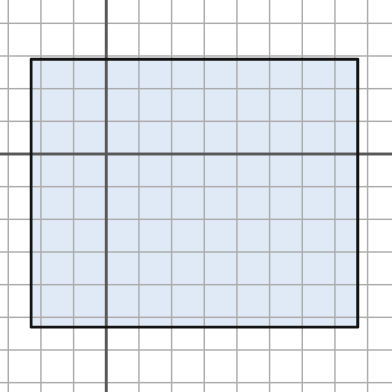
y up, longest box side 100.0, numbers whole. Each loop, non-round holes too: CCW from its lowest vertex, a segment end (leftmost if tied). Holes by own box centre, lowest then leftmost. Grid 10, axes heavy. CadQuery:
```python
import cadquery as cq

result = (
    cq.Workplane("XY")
    .moveTo(-23.0, -53.0)
    .lineTo(77.0, -53.0)
    .lineTo(77.0, 29.0)
    .lineTo(-23.0, 29.0)
    .close()
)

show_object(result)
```